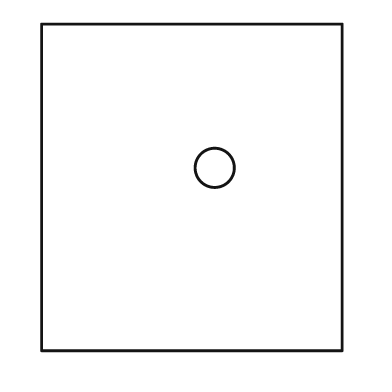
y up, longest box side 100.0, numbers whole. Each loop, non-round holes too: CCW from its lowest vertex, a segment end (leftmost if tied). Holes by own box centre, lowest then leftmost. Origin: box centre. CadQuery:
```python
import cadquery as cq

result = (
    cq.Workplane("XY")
    .moveTo(-46.0, -50.0)
    .lineTo(46.0, -50.0)
    .lineTo(46.0, 50.0)
    .lineTo(-46.0, 50.0)
    .close()
    .moveTo(7.0, 6.0)
    .circle(6.0)
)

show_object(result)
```